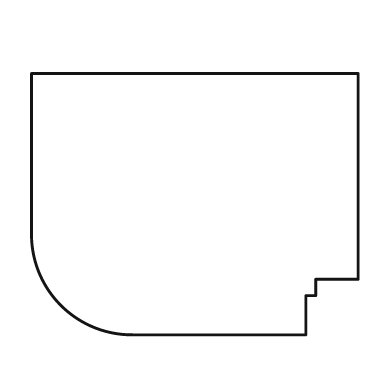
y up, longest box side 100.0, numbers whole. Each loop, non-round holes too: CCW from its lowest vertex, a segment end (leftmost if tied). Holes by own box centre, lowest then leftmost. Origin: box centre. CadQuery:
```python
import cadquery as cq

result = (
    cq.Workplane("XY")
    .moveTo(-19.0, -40.0)
    .lineTo(34.0, -40.0)
    .lineTo(34.0, -28.0)
    .lineTo(37.0, -28.0)
    .lineTo(37.0, -23.0)
    .lineTo(50.0, -23.0)
    .lineTo(50.0, 40.0)
    .lineTo(-50.0, 40.0)
    .lineTo(-50.0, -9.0)
    .threePointArc((-41.0, -31.0), (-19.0, -40.0))
    .close()
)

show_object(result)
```